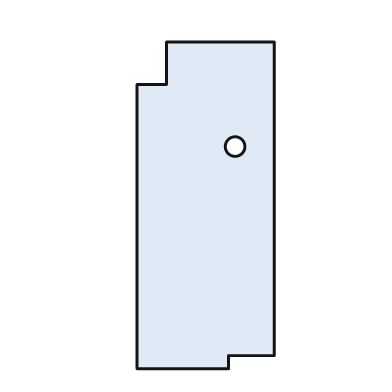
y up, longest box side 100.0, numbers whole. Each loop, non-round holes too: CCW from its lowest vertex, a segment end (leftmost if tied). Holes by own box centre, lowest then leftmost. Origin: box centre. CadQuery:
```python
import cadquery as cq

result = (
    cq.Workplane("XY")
    .moveTo(-21.0, -50.0)
    .lineTo(7.0, -50.0)
    .lineTo(7.0, -46.0)
    .lineTo(21.0, -46.0)
    .lineTo(21.0, 50.0)
    .lineTo(-12.0, 50.0)
    .lineTo(-12.0, 37.0)
    .lineTo(-21.0, 37.0)
    .close()
    .moveTo(9.0, 18.0)
    .circle(3.0)
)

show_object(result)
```